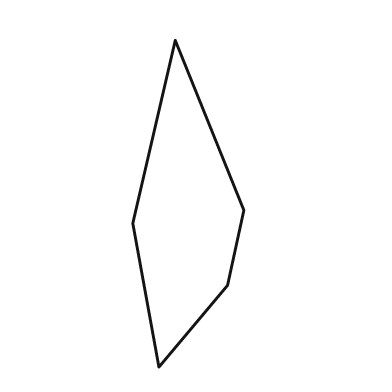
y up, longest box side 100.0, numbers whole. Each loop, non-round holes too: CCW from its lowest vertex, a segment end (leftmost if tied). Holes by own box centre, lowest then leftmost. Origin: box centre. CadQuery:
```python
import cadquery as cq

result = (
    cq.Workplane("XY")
    .moveTo(-9.0, -50.0)
    .lineTo(12.0, -25.0)
    .lineTo(17.0, -2.0)
    .lineTo(-4.0, 50.0)
    .lineTo(-17.0, -6.0)
    .close()
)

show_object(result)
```